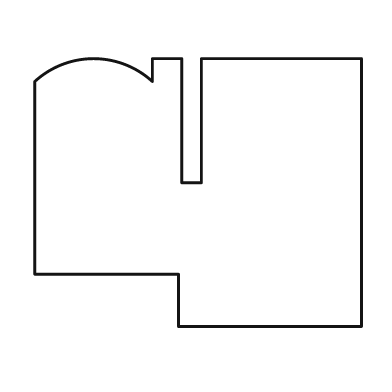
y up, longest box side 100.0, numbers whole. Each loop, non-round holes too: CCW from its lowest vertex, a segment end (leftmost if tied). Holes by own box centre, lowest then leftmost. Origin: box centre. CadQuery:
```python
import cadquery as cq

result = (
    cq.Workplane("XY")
    .moveTo(-6.0, -41.0)
    .lineTo(50.0, -41.0)
    .lineTo(50.0, 41.0)
    .lineTo(1.0, 41.0)
    .lineTo(1.0, 3.0)
    .lineTo(-5.0, 3.0)
    .lineTo(-5.0, 41.0)
    .lineTo(-14.0, 41.0)
    .lineTo(-14.0, 34.0)
    .threePointArc((-32.0, 41.0), (-50.0, 34.0))
    .lineTo(-50.0, -25.0)
    .lineTo(-6.0, -25.0)
    .close()
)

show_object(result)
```